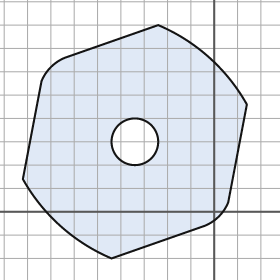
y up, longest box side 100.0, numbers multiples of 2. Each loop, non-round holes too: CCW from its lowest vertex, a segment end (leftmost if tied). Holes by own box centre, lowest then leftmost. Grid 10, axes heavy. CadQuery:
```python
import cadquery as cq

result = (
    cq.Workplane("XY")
    .moveTo(-44.0, -20.0)
    .lineTo(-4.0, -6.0)
    .threePointArc((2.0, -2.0), (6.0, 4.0))
    .lineTo(14.0, 46.0)
    .threePointArc((-2.0, 66.0), (-24.0, 80.0))
    .lineTo(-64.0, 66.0)
    .threePointArc((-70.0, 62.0), (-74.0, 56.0))
    .lineTo(-82.0, 14.0)
    .threePointArc((-66.0, -6.0), (-44.0, -20.0))
    .close()
    .moveTo(-34.0, 30.0)
    .circle(10.0)
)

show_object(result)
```